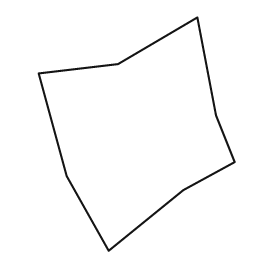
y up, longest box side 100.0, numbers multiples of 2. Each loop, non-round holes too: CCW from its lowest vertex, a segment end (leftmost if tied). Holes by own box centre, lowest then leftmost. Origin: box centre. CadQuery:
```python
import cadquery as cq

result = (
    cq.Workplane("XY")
    .moveTo(-12.0, -50.0)
    .lineTo(20.0, -24.0)
    .lineTo(42.0, -12.0)
    .lineTo(34.0, 8.0)
    .lineTo(26.0, 50.0)
    .lineTo(-8.0, 30.0)
    .lineTo(-42.0, 26.0)
    .lineTo(-30.0, -18.0)
    .close()
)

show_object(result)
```